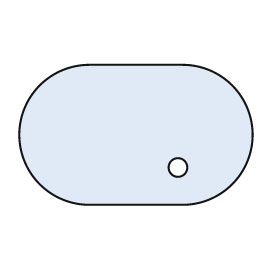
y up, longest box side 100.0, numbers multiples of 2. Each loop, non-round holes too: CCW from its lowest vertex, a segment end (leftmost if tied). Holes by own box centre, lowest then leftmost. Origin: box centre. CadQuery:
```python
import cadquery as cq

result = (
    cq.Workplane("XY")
    .moveTo(-20.0, -30.0)
    .lineTo(20.0, -30.0)
    .threePointArc((50.0, 0.0), (20.0, 30.0))
    .lineTo(-20.0, 30.0)
    .threePointArc((-50.0, 0.0), (-20.0, -30.0))
    .close()
    .moveTo(18.0, -14.0)
    .circle(4.0)
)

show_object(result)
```